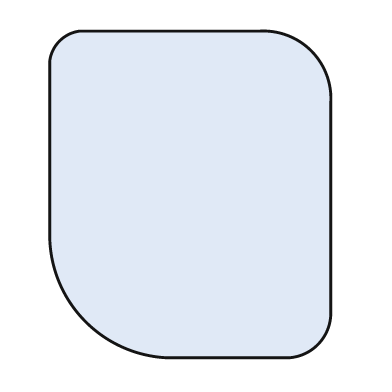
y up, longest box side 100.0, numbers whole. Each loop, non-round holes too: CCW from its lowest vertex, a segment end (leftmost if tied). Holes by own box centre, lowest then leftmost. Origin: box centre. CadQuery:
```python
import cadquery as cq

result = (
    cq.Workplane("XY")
    .moveTo(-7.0, -50.0)
    .lineTo(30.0, -50.0)
    .threePointArc((39.0, -46.0), (43.0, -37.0))
    .lineTo(43.0, 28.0)
    .threePointArc((37.0, 44.0), (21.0, 50.0))
    .lineTo(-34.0, 50.0)
    .threePointArc((-40.0, 47.0), (-43.0, 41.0))
    .lineTo(-43.0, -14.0)
    .threePointArc((-32.0, -39.0), (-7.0, -50.0))
    .close()
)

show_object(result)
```